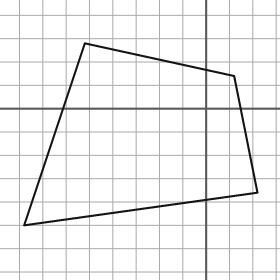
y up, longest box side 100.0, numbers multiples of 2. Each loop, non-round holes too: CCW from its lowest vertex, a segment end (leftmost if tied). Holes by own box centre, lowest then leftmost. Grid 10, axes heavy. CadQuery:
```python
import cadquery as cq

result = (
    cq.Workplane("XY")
    .moveTo(-78.0, -50.0)
    .lineTo(22.0, -36.0)
    .lineTo(12.0, 14.0)
    .lineTo(-52.0, 28.0)
    .close()
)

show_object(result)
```